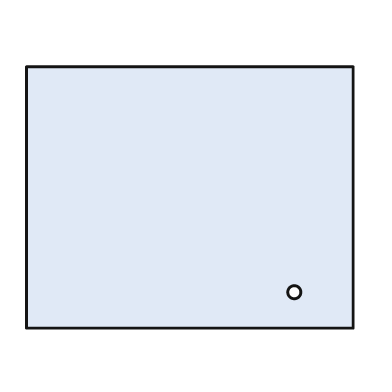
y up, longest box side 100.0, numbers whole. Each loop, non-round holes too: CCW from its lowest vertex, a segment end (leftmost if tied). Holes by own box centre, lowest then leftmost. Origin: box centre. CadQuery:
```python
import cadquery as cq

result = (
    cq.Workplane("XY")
    .moveTo(-50.0, -40.0)
    .lineTo(50.0, -40.0)
    .lineTo(50.0, 40.0)
    .lineTo(-50.0, 40.0)
    .close()
    .moveTo(32.0, -29.0)
    .circle(2.0)
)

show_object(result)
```